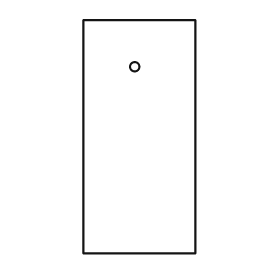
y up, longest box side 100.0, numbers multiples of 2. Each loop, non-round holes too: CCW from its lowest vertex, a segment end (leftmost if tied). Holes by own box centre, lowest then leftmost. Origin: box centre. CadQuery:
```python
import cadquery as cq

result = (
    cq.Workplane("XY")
    .moveTo(-24.0, -50.0)
    .lineTo(24.0, -50.0)
    .lineTo(24.0, 50.0)
    .lineTo(-24.0, 50.0)
    .close()
    .moveTo(-2.0, 30.0)
    .circle(2.0)
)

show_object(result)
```